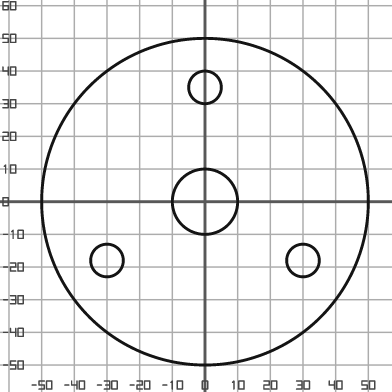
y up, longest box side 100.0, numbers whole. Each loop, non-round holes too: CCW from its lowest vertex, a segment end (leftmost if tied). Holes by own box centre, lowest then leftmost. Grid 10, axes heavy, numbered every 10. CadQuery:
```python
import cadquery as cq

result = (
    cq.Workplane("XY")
    .moveTo(0.0, 0.0)
    .circle(50.0)
    .moveTo(-30.0, -18.0)
    .circle(5.0)
    .moveTo(30.0, -18.0)
    .circle(5.0)
    .moveTo(0.0, 0.0)
    .circle(10.0)
    .moveTo(0.0, 35.0)
    .circle(5.0)
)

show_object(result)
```